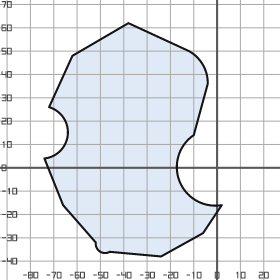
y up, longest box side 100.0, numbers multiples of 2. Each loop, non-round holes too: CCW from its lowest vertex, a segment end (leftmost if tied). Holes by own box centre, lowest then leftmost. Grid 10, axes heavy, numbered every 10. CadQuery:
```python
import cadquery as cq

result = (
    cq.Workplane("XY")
    .moveTo(-24.0, -38.0)
    .lineTo(-6.0, -28.0)
    .lineTo(2.0, -16.0)
    .threePointArc((-16.0, -6.0), (-10.0, 14.0))
    .lineTo(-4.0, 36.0)
    .threePointArc((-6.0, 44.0), (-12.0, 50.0))
    .lineTo(-38.0, 62.0)
    .lineTo(-62.0, 48.0)
    .lineTo(-72.0, 26.0)
    .threePointArc((-64.0, 14.0), (-74.0, 4.0))
    .lineTo(-66.0, -16.0)
    .lineTo(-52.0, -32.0)
    .threePointArc((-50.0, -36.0), (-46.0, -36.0))
    .close()
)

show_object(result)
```